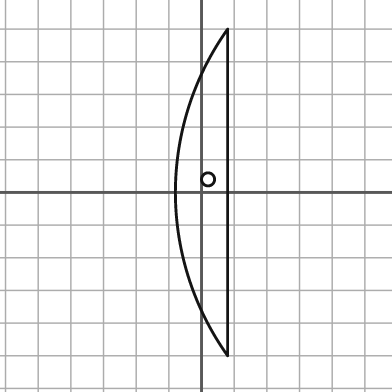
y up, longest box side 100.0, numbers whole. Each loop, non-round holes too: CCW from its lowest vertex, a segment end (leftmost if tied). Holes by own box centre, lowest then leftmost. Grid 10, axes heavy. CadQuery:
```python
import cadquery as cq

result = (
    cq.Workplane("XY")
    .moveTo(8.0, -50.0)
    .lineTo(8.0, 50.0)
    .threePointArc((-8.0, 0.0), (8.0, -50.0))
    .close()
    .moveTo(2.0, 4.0)
    .circle(2.0)
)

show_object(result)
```